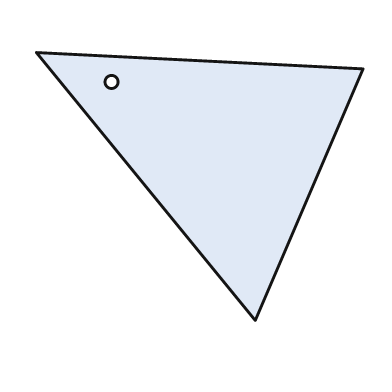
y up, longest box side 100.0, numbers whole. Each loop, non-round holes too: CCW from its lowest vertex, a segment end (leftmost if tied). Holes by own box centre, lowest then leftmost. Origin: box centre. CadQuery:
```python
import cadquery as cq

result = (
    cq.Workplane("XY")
    .moveTo(17.0, -41.0)
    .lineTo(50.0, 36.0)
    .lineTo(-50.0, 41.0)
    .close()
    .moveTo(-27.0, 32.0)
    .circle(2.0)
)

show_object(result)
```